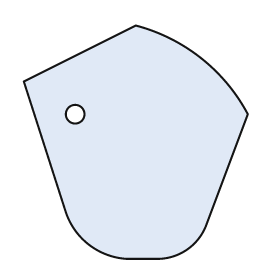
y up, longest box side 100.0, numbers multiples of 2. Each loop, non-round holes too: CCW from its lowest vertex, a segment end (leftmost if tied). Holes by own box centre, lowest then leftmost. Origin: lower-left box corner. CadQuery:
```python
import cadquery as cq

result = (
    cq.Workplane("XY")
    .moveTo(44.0, 0.0)
    .lineTo(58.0, 0.0)
    .threePointArc((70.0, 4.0), (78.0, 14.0))
    .lineTo(96.0, 62.0)
    .threePointArc((76.0, 86.0), (48.0, 100.0))
    .lineTo(0.0, 76.0)
    .lineTo(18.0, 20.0)
    .threePointArc((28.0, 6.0), (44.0, 0.0))
    .close()
    .moveTo(22.0, 62.0)
    .circle(4.0)
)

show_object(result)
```